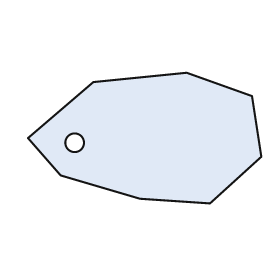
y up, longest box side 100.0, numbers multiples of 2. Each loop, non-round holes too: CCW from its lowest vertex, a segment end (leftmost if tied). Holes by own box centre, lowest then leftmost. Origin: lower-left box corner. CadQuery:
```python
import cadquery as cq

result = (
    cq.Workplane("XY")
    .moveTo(78.0, 0.0)
    .lineTo(100.0, 20.0)
    .lineTo(96.0, 46.0)
    .lineTo(68.0, 56.0)
    .lineTo(28.0, 52.0)
    .lineTo(0.0, 28.0)
    .lineTo(14.0, 12.0)
    .lineTo(48.0, 2.0)
    .close()
    .moveTo(20.0, 26.0)
    .circle(4.0)
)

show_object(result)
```